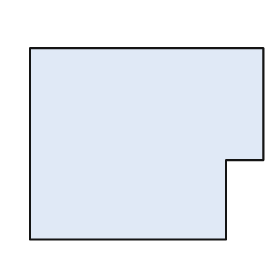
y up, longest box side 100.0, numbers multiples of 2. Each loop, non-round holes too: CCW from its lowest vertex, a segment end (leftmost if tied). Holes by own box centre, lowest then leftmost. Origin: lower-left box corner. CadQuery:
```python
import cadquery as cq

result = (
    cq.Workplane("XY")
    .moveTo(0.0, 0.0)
    .lineTo(84.0, 0.0)
    .lineTo(84.0, 34.0)
    .lineTo(100.0, 34.0)
    .lineTo(100.0, 82.0)
    .lineTo(0.0, 82.0)
    .close()
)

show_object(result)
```